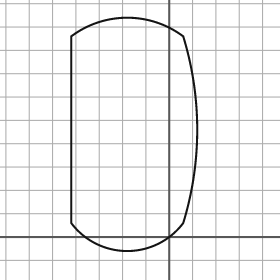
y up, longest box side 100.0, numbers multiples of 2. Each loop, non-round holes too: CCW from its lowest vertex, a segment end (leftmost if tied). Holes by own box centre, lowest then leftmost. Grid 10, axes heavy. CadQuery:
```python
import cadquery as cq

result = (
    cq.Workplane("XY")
    .moveTo(-42.0, 6.0)
    .threePointArc((-18.0, -6.0), (6.0, 6.0))
    .threePointArc((12.0, 46.0), (6.0, 86.0))
    .threePointArc((-18.0, 94.0), (-42.0, 86.0))
    .close()
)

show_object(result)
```